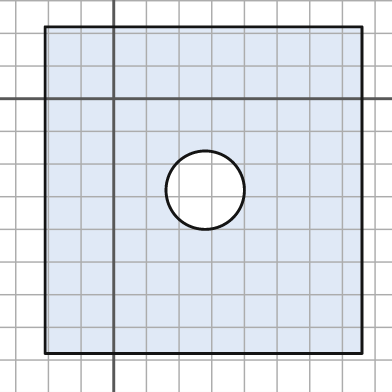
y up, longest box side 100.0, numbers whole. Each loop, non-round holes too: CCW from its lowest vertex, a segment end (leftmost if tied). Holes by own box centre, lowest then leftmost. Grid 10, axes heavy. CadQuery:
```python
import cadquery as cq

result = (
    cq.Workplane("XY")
    .moveTo(-21.0, -78.0)
    .lineTo(76.0, -78.0)
    .lineTo(76.0, 22.0)
    .lineTo(-21.0, 22.0)
    .close()
    .moveTo(28.0, -28.0)
    .circle(12.0)
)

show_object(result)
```